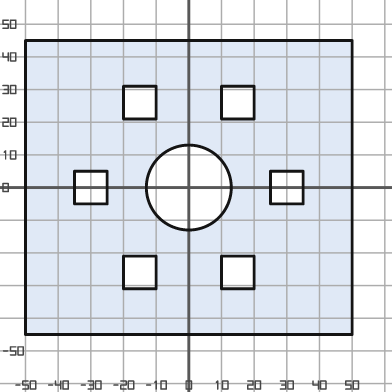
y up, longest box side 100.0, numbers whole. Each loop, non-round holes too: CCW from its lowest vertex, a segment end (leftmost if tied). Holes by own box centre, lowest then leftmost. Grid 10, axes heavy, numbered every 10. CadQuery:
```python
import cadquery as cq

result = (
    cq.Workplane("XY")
    .moveTo(-50.0, -45.0)
    .lineTo(50.0, -45.0)
    .lineTo(50.0, 45.0)
    .lineTo(-50.0, 45.0)
    .close()
    .moveTo(-20.0, -31.0)
    .lineTo(-10.0, -31.0)
    .lineTo(-10.0, -21.0)
    .lineTo(-20.0, -21.0)
    .close()
    .moveTo(10.0, -31.0)
    .lineTo(20.0, -31.0)
    .lineTo(20.0, -21.0)
    .lineTo(10.0, -21.0)
    .close()
    .moveTo(-35.0, -5.0)
    .lineTo(-25.0, -5.0)
    .lineTo(-25.0, 5.0)
    .lineTo(-35.0, 5.0)
    .close()
    .moveTo(0.0, 0.0)
    .circle(13.0)
    .moveTo(25.0, -5.0)
    .lineTo(35.0, -5.0)
    .lineTo(35.0, 5.0)
    .lineTo(25.0, 5.0)
    .close()
    .moveTo(-20.0, 21.0)
    .lineTo(-10.0, 21.0)
    .lineTo(-10.0, 31.0)
    .lineTo(-20.0, 31.0)
    .close()
    .moveTo(10.0, 21.0)
    .lineTo(20.0, 21.0)
    .lineTo(20.0, 31.0)
    .lineTo(10.0, 31.0)
    .close()
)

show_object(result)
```